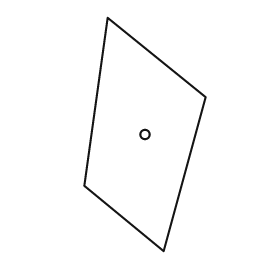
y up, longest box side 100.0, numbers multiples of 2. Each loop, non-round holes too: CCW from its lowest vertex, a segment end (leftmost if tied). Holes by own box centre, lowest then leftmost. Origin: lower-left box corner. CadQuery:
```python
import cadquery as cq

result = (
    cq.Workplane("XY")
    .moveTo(34.0, 0.0)
    .lineTo(52.0, 66.0)
    .lineTo(10.0, 100.0)
    .lineTo(0.0, 28.0)
    .close()
    .moveTo(26.0, 50.0)
    .circle(2.0)
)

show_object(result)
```